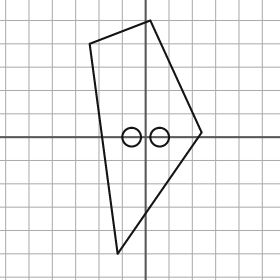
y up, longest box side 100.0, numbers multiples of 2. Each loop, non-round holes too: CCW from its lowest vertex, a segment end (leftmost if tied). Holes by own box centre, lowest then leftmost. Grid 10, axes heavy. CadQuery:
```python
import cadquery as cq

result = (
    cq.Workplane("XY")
    .moveTo(-12.0, -50.0)
    .lineTo(24.0, 2.0)
    .lineTo(2.0, 50.0)
    .lineTo(-24.0, 40.0)
    .close()
    .moveTo(-6.0, 0.0)
    .circle(4.0)
    .moveTo(6.0, 0.0)
    .circle(4.0)
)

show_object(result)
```